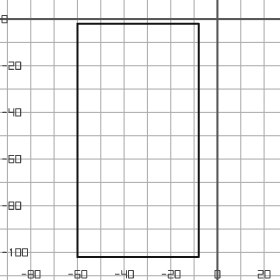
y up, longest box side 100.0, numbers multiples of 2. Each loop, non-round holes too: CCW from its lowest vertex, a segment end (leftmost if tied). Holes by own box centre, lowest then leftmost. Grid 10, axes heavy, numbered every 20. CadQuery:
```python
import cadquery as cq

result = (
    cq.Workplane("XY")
    .moveTo(-60.0, -102.0)
    .lineTo(-8.0, -102.0)
    .lineTo(-8.0, -2.0)
    .lineTo(-60.0, -2.0)
    .close()
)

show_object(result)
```